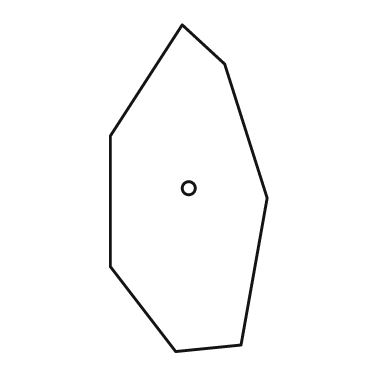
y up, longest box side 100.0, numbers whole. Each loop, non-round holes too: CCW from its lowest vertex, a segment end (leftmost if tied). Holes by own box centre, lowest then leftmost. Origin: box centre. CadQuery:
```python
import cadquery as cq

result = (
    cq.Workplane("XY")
    .moveTo(-4.0, -50.0)
    .lineTo(16.0, -48.0)
    .lineTo(24.0, -3.0)
    .lineTo(11.0, 38.0)
    .lineTo(-2.0, 50.0)
    .lineTo(-24.0, 16.0)
    .lineTo(-24.0, -24.0)
    .close()
    .moveTo(0.0, 0.0)
    .circle(2.0)
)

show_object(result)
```